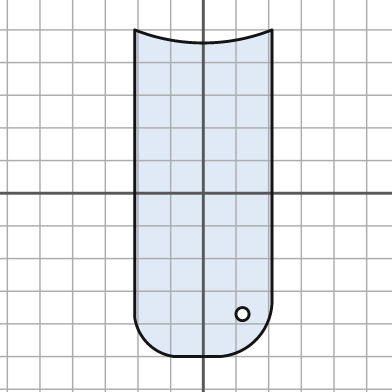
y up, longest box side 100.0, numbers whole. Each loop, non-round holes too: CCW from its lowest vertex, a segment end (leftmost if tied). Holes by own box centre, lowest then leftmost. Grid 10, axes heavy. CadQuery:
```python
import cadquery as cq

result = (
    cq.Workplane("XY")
    .moveTo(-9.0, -50.0)
    .lineTo(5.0, -50.0)
    .threePointArc((16.0, -45.0), (21.0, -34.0))
    .lineTo(21.0, 50.0)
    .threePointArc((0.0, 46.0), (-21.0, 50.0))
    .lineTo(-21.0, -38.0)
    .threePointArc((-17.0, -46.0), (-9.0, -50.0))
    .close()
    .moveTo(12.0, -37.0)
    .circle(2.0)
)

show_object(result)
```